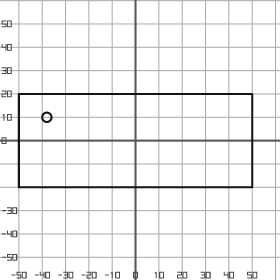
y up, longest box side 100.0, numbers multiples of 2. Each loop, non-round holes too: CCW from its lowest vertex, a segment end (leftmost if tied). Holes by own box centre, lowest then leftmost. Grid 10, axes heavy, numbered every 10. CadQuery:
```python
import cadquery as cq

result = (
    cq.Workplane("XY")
    .moveTo(-50.0, -20.0)
    .lineTo(50.0, -20.0)
    .lineTo(50.0, 20.0)
    .lineTo(-50.0, 20.0)
    .close()
    .moveTo(-38.0, 10.0)
    .circle(2.0)
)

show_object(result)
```